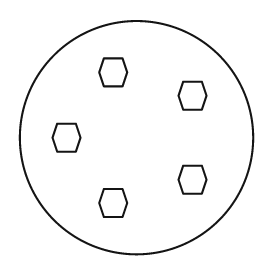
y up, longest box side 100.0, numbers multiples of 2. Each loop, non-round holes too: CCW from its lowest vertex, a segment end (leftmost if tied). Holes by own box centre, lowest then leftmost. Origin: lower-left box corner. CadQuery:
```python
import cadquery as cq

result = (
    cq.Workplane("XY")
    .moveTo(50.0, 50.0)
    .circle(50.0)
    .moveTo(36.0, 16.0)
    .lineTo(44.0, 16.0)
    .lineTo(46.0, 22.0)
    .lineTo(44.0, 28.0)
    .lineTo(36.0, 28.0)
    .lineTo(34.0, 22.0)
    .close()
    .moveTo(70.0, 26.0)
    .lineTo(78.0, 26.0)
    .lineTo(80.0, 32.0)
    .lineTo(78.0, 38.0)
    .lineTo(70.0, 38.0)
    .lineTo(68.0, 32.0)
    .close()
    .moveTo(16.0, 44.0)
    .lineTo(24.0, 44.0)
    .lineTo(26.0, 50.0)
    .lineTo(24.0, 56.0)
    .lineTo(16.0, 56.0)
    .lineTo(14.0, 50.0)
    .close()
    .moveTo(70.0, 62.0)
    .lineTo(78.0, 62.0)
    .lineTo(80.0, 68.0)
    .lineTo(78.0, 74.0)
    .lineTo(70.0, 74.0)
    .lineTo(68.0, 68.0)
    .close()
    .moveTo(36.0, 72.0)
    .lineTo(44.0, 72.0)
    .lineTo(46.0, 78.0)
    .lineTo(44.0, 84.0)
    .lineTo(36.0, 84.0)
    .lineTo(34.0, 78.0)
    .close()
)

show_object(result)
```